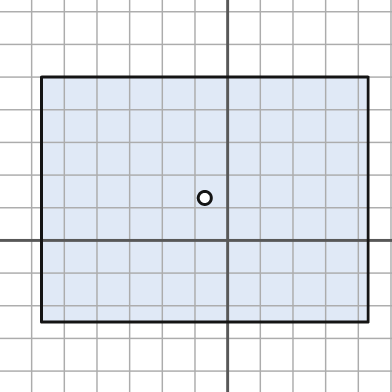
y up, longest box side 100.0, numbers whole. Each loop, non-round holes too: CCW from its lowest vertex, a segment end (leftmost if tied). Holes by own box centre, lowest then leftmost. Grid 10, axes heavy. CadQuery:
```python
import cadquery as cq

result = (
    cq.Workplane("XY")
    .moveTo(-57.0, -25.0)
    .lineTo(43.0, -25.0)
    .lineTo(43.0, 50.0)
    .lineTo(-57.0, 50.0)
    .close()
    .moveTo(-7.0, 13.0)
    .circle(2.0)
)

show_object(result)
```